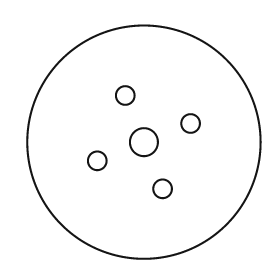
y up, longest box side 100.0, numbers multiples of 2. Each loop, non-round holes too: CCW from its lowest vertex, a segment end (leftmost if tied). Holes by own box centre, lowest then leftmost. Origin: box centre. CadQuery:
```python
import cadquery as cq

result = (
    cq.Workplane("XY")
    .moveTo(0.0, 0.0)
    .circle(50.0)
    .moveTo(8.0, -20.0)
    .circle(4.0)
    .moveTo(-20.0, -8.0)
    .circle(4.0)
    .moveTo(0.0, 0.0)
    .circle(6.0)
    .moveTo(20.0, 8.0)
    .circle(4.0)
    .moveTo(-8.0, 20.0)
    .circle(4.0)
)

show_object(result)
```